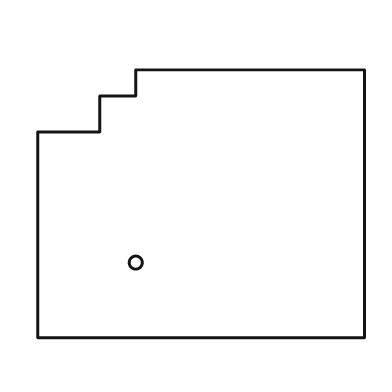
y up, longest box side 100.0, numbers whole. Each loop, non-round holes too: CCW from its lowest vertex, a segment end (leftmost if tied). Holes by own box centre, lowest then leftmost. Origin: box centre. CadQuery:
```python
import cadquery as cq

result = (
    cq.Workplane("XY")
    .moveTo(-50.0, -41.0)
    .lineTo(50.0, -41.0)
    .lineTo(50.0, 41.0)
    .lineTo(-20.0, 41.0)
    .lineTo(-20.0, 33.0)
    .lineTo(-31.0, 33.0)
    .lineTo(-31.0, 22.0)
    .lineTo(-50.0, 22.0)
    .close()
    .moveTo(-20.0, -18.0)
    .circle(2.0)
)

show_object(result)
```